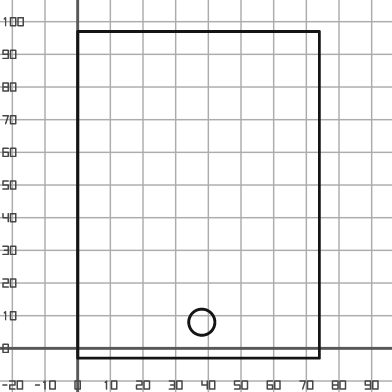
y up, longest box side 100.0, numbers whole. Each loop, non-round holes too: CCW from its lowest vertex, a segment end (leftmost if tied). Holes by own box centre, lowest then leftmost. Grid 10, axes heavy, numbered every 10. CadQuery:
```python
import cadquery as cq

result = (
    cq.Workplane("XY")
    .moveTo(0.0, -3.0)
    .lineTo(74.0, -3.0)
    .lineTo(74.0, 97.0)
    .lineTo(0.0, 97.0)
    .close()
    .moveTo(38.0, 8.0)
    .circle(4.0)
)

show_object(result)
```